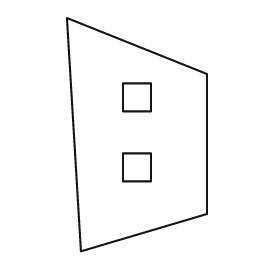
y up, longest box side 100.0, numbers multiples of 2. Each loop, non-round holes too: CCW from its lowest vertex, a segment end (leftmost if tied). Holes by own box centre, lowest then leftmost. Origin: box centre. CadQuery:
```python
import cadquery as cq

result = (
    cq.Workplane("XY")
    .moveTo(-24.0, -50.0)
    .lineTo(30.0, -34.0)
    .lineTo(30.0, 26.0)
    .lineTo(-30.0, 50.0)
    .close()
    .moveTo(-6.0, -20.0)
    .lineTo(6.0, -20.0)
    .lineTo(6.0, -8.0)
    .lineTo(-6.0, -8.0)
    .close()
    .moveTo(-6.0, 10.0)
    .lineTo(6.0, 10.0)
    .lineTo(6.0, 22.0)
    .lineTo(-6.0, 22.0)
    .close()
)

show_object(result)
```